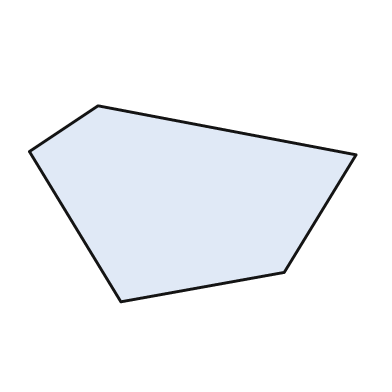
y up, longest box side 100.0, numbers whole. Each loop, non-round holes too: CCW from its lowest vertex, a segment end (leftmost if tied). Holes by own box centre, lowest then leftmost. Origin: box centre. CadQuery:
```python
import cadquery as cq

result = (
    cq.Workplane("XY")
    .moveTo(-22.0, -30.0)
    .lineTo(28.0, -21.0)
    .lineTo(50.0, 15.0)
    .lineTo(-29.0, 30.0)
    .lineTo(-50.0, 16.0)
    .close()
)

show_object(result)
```